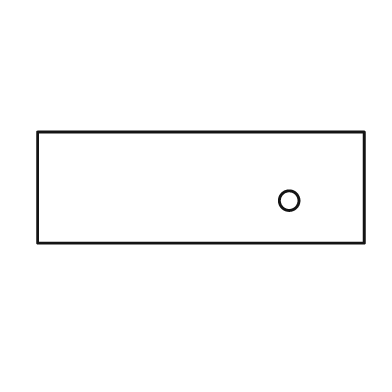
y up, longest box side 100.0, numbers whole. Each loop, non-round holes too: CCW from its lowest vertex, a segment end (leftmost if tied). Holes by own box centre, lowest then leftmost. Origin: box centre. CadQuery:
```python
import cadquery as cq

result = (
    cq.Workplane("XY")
    .moveTo(-50.0, -17.0)
    .lineTo(50.0, -17.0)
    .lineTo(50.0, 17.0)
    .lineTo(-50.0, 17.0)
    .close()
    .moveTo(27.0, -4.0)
    .circle(3.0)
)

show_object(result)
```